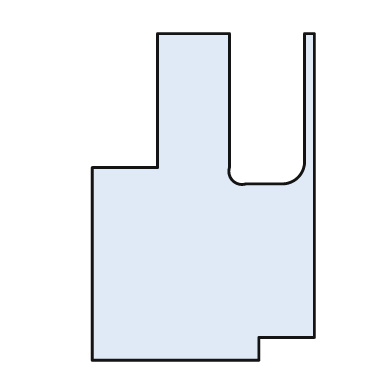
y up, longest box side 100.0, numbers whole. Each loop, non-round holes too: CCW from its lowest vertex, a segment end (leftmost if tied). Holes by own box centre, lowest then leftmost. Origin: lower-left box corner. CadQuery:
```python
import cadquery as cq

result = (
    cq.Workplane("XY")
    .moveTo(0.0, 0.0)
    .lineTo(51.0, 0.0)
    .lineTo(51.0, 7.0)
    .lineTo(68.0, 7.0)
    .lineTo(68.0, 100.0)
    .lineTo(65.0, 100.0)
    .lineTo(65.0, 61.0)
    .threePointArc((63.0, 56.0), (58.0, 54.0))
    .lineTo(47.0, 54.0)
    .threePointArc((43.0, 55.0), (42.0, 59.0))
    .lineTo(42.0, 100.0)
    .lineTo(20.0, 100.0)
    .lineTo(20.0, 59.0)
    .lineTo(0.0, 59.0)
    .close()
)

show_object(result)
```